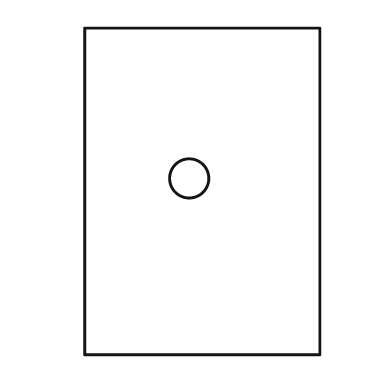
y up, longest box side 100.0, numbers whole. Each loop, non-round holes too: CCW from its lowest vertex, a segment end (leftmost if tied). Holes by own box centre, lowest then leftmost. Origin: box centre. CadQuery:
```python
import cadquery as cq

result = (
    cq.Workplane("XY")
    .moveTo(-36.0, -50.0)
    .lineTo(36.0, -50.0)
    .lineTo(36.0, 50.0)
    .lineTo(-36.0, 50.0)
    .close()
    .moveTo(-4.0, 4.0)
    .circle(6.0)
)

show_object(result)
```